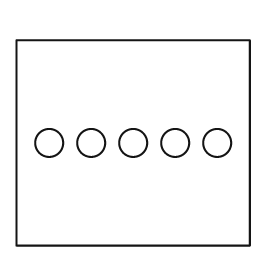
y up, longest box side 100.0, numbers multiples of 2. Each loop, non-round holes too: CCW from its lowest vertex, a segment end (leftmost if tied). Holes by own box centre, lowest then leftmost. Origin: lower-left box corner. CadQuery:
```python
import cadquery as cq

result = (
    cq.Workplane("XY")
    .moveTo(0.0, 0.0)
    .lineTo(100.0, 0.0)
    .lineTo(100.0, 88.0)
    .lineTo(0.0, 88.0)
    .close()
    .moveTo(14.0, 44.0)
    .circle(6.0)
    .moveTo(32.0, 44.0)
    .circle(6.0)
    .moveTo(50.0, 44.0)
    .circle(6.0)
    .moveTo(68.0, 44.0)
    .circle(6.0)
    .moveTo(86.0, 44.0)
    .circle(6.0)
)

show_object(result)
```